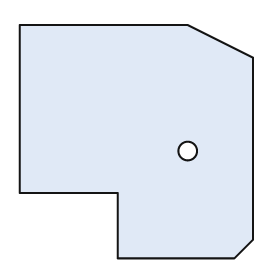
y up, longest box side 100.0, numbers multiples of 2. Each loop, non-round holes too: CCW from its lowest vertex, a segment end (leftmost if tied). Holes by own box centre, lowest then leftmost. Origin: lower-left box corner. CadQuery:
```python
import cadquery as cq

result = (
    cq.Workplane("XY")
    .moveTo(42.0, 0.0)
    .lineTo(92.0, 0.0)
    .lineTo(100.0, 8.0)
    .lineTo(100.0, 86.0)
    .lineTo(72.0, 100.0)
    .lineTo(0.0, 100.0)
    .lineTo(0.0, 28.0)
    .lineTo(42.0, 28.0)
    .close()
    .moveTo(72.0, 46.0)
    .circle(4.0)
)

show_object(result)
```